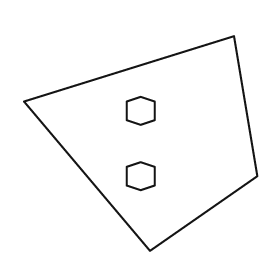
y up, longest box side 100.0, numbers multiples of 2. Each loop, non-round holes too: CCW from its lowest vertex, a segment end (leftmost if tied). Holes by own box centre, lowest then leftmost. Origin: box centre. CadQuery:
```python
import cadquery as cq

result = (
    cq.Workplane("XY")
    .moveTo(4.0, -46.0)
    .lineTo(50.0, -14.0)
    .lineTo(40.0, 46.0)
    .lineTo(-50.0, 18.0)
    .close()
    .moveTo(0.0, -20.0)
    .lineTo(6.0, -18.0)
    .lineTo(6.0, -10.0)
    .lineTo(0.0, -8.0)
    .lineTo(-6.0, -10.0)
    .lineTo(-6.0, -18.0)
    .close()
    .moveTo(0.0, 8.0)
    .lineTo(6.0, 10.0)
    .lineTo(6.0, 18.0)
    .lineTo(0.0, 20.0)
    .lineTo(-6.0, 18.0)
    .lineTo(-6.0, 10.0)
    .close()
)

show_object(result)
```